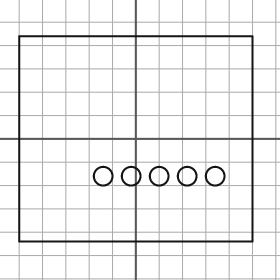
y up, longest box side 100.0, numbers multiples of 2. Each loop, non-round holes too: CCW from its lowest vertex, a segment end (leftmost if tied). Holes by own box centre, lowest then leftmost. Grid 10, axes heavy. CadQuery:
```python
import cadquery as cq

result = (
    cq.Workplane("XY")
    .moveTo(-50.0, -44.0)
    .lineTo(50.0, -44.0)
    .lineTo(50.0, 44.0)
    .lineTo(-50.0, 44.0)
    .close()
    .moveTo(-14.0, -16.0)
    .circle(4.0)
    .moveTo(-2.0, -16.0)
    .circle(4.0)
    .moveTo(10.0, -16.0)
    .circle(4.0)
    .moveTo(22.0, -16.0)
    .circle(4.0)
    .moveTo(34.0, -16.0)
    .circle(4.0)
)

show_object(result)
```